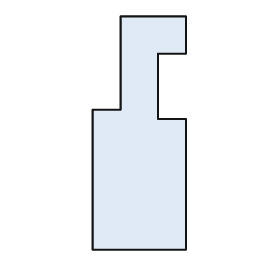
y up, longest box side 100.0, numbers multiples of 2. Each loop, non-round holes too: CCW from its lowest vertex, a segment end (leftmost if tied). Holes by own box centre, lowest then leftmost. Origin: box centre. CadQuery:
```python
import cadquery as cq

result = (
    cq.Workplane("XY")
    .moveTo(-20.0, -50.0)
    .lineTo(20.0, -50.0)
    .lineTo(20.0, 6.0)
    .lineTo(8.0, 6.0)
    .lineTo(8.0, 34.0)
    .lineTo(20.0, 34.0)
    .lineTo(20.0, 50.0)
    .lineTo(-8.0, 50.0)
    .lineTo(-8.0, 10.0)
    .lineTo(-20.0, 10.0)
    .close()
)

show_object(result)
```